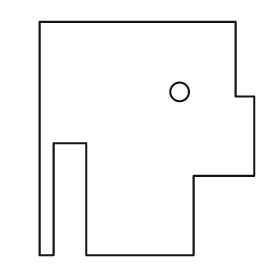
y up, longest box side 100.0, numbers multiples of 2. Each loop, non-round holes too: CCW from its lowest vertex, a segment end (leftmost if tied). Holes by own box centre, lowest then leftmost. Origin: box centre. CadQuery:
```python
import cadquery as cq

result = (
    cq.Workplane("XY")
    .moveTo(-46.0, -50.0)
    .lineTo(-40.0, -50.0)
    .lineTo(-40.0, -2.0)
    .lineTo(-26.0, -2.0)
    .lineTo(-26.0, -50.0)
    .lineTo(20.0, -50.0)
    .lineTo(20.0, -16.0)
    .lineTo(46.0, -16.0)
    .lineTo(46.0, 18.0)
    .lineTo(38.0, 18.0)
    .lineTo(38.0, 50.0)
    .lineTo(-46.0, 50.0)
    .close()
    .moveTo(14.0, 20.0)
    .circle(4.0)
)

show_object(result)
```